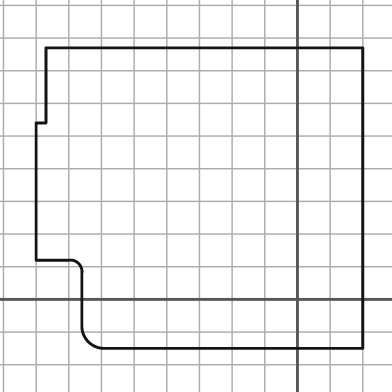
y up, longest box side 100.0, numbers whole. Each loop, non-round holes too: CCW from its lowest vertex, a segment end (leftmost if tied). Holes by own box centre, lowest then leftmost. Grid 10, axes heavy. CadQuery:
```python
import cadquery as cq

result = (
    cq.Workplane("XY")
    .moveTo(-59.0, -15.0)
    .lineTo(20.0, -15.0)
    .lineTo(20.0, 77.0)
    .lineTo(-77.0, 77.0)
    .lineTo(-77.0, 54.0)
    .lineTo(-80.0, 54.0)
    .lineTo(-80.0, 12.0)
    .lineTo(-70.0, 12.0)
    .threePointArc((-67.0, 11.0), (-66.0, 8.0))
    .lineTo(-66.0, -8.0)
    .threePointArc((-64.0, -13.0), (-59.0, -15.0))
    .close()
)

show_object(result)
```